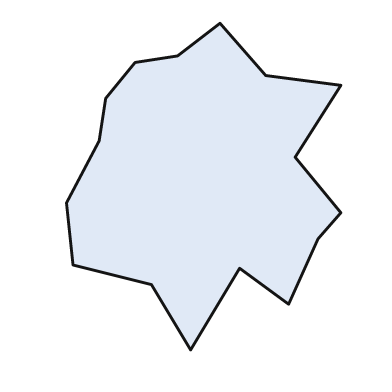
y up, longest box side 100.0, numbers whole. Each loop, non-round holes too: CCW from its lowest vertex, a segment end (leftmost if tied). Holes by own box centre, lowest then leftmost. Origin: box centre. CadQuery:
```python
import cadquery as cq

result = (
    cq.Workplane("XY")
    .moveTo(-4.0, -50.0)
    .lineTo(11.0, -25.0)
    .lineTo(26.0, -36.0)
    .lineTo(35.0, -16.0)
    .lineTo(42.0, -8.0)
    .lineTo(28.0, 9.0)
    .lineTo(42.0, 31.0)
    .lineTo(19.0, 34.0)
    .lineTo(5.0, 50.0)
    .lineTo(-8.0, 40.0)
    .lineTo(-21.0, 38.0)
    .lineTo(-30.0, 27.0)
    .lineTo(-32.0, 14.0)
    .lineTo(-42.0, -5.0)
    .lineTo(-40.0, -24.0)
    .lineTo(-16.0, -30.0)
    .close()
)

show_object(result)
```